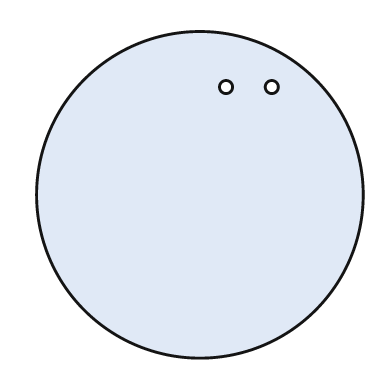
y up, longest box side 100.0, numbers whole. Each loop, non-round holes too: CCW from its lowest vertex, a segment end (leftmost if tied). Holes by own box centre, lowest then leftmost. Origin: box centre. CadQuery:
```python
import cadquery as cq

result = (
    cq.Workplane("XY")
    .moveTo(0.0, 0.0)
    .circle(50.0)
    .moveTo(8.0, 33.0)
    .circle(2.0)
    .moveTo(22.0, 33.0)
    .circle(2.0)
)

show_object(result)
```